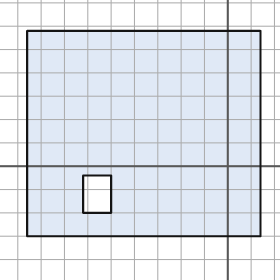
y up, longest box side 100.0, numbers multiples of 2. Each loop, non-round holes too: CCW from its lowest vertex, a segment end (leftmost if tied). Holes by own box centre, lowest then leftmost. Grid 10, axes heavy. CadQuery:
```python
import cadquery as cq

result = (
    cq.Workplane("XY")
    .moveTo(-86.0, -30.0)
    .lineTo(14.0, -30.0)
    .lineTo(14.0, 58.0)
    .lineTo(-86.0, 58.0)
    .close()
    .moveTo(-62.0, -20.0)
    .lineTo(-50.0, -20.0)
    .lineTo(-50.0, -4.0)
    .lineTo(-62.0, -4.0)
    .close()
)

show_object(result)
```